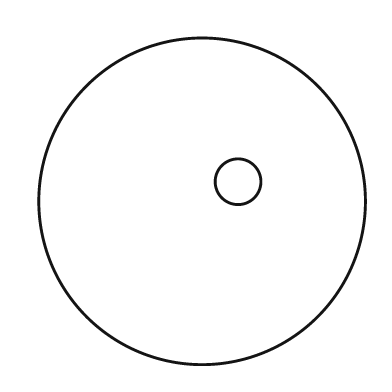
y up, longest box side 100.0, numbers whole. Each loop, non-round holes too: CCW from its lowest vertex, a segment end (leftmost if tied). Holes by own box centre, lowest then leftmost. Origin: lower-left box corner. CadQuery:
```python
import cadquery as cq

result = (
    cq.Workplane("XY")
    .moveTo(50.0, 50.0)
    .circle(50.0)
    .moveTo(61.0, 56.0)
    .circle(7.0)
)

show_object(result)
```